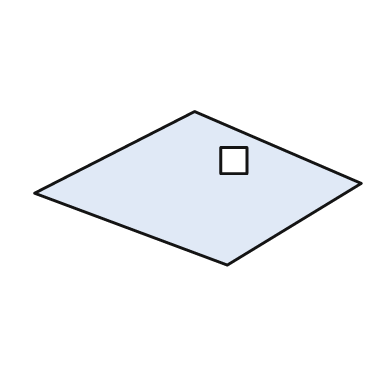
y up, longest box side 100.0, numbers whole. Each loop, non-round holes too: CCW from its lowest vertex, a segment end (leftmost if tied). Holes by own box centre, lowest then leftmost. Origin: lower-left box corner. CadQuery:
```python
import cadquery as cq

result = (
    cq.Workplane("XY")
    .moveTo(59.0, 0.0)
    .lineTo(100.0, 25.0)
    .lineTo(49.0, 47.0)
    .lineTo(0.0, 22.0)
    .close()
    .moveTo(57.0, 28.0)
    .lineTo(65.0, 28.0)
    .lineTo(65.0, 36.0)
    .lineTo(57.0, 36.0)
    .close()
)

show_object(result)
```